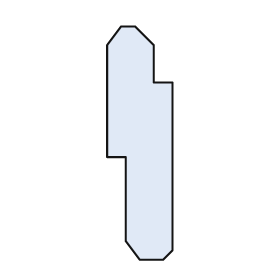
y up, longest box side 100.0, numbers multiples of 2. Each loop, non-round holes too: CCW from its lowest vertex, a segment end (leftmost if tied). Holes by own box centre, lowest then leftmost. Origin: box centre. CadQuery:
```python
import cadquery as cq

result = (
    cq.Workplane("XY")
    .moveTo(0.0, -50.0)
    .lineTo(10.0, -50.0)
    .lineTo(14.0, -46.0)
    .lineTo(14.0, 26.0)
    .lineTo(6.0, 26.0)
    .lineTo(6.0, 42.0)
    .lineTo(-2.0, 50.0)
    .lineTo(-8.0, 50.0)
    .lineTo(-14.0, 42.0)
    .lineTo(-14.0, -6.0)
    .lineTo(-6.0, -6.0)
    .lineTo(-6.0, -42.0)
    .close()
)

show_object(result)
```